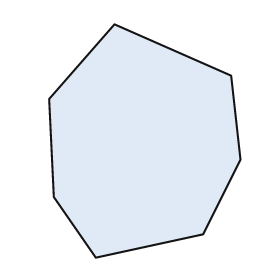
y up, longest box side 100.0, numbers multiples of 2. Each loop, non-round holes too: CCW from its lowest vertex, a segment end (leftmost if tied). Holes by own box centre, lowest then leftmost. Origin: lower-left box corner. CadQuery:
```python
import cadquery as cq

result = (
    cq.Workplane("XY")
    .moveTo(20.0, 0.0)
    .lineTo(66.0, 10.0)
    .lineTo(82.0, 42.0)
    .lineTo(78.0, 78.0)
    .lineTo(28.0, 100.0)
    .lineTo(0.0, 68.0)
    .lineTo(2.0, 26.0)
    .close()
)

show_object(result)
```